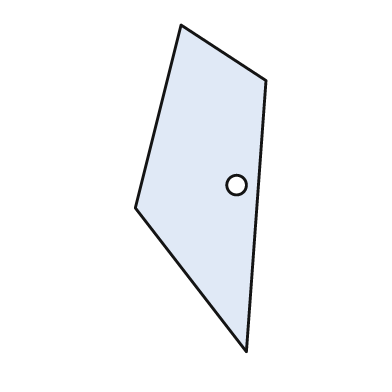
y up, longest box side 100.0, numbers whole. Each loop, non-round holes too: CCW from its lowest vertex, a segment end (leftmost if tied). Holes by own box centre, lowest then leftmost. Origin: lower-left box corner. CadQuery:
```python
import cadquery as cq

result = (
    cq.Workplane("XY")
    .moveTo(34.0, 0.0)
    .lineTo(40.0, 83.0)
    .lineTo(14.0, 100.0)
    .lineTo(0.0, 44.0)
    .close()
    .moveTo(31.0, 51.0)
    .circle(3.0)
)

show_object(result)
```